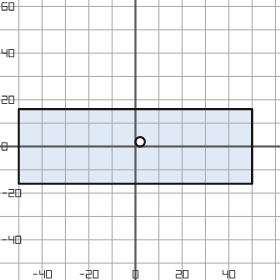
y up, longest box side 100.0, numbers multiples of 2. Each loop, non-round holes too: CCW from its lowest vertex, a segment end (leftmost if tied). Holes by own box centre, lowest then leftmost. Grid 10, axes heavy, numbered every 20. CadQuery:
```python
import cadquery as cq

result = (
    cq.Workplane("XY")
    .moveTo(-50.0, -16.0)
    .lineTo(50.0, -16.0)
    .lineTo(50.0, 16.0)
    .lineTo(-50.0, 16.0)
    .close()
    .moveTo(2.0, 2.0)
    .circle(2.0)
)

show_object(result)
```